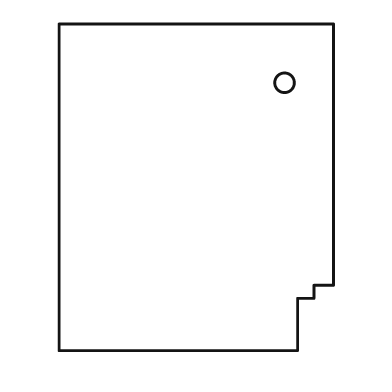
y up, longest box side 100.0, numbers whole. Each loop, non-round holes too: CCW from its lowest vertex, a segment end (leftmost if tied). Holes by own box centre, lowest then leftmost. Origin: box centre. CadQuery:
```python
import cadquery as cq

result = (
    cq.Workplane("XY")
    .moveTo(-42.0, -50.0)
    .lineTo(31.0, -50.0)
    .lineTo(31.0, -34.0)
    .lineTo(36.0, -34.0)
    .lineTo(36.0, -30.0)
    .lineTo(42.0, -30.0)
    .lineTo(42.0, 50.0)
    .lineTo(-42.0, 50.0)
    .close()
    .moveTo(27.0, 32.0)
    .circle(3.0)
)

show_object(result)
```